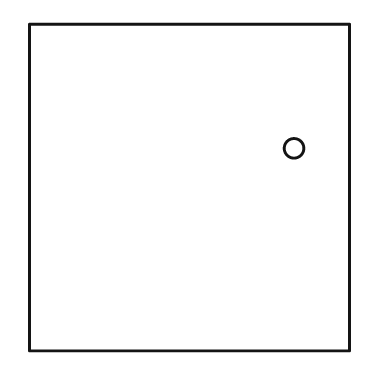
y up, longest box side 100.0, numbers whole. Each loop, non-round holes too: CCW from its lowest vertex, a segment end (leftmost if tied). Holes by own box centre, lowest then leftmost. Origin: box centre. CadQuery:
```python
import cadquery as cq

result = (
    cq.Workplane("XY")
    .moveTo(-49.0, -50.0)
    .lineTo(49.0, -50.0)
    .lineTo(49.0, 50.0)
    .lineTo(-49.0, 50.0)
    .close()
    .moveTo(32.0, 12.0)
    .circle(3.0)
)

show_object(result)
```